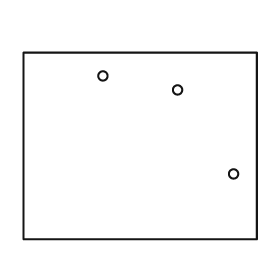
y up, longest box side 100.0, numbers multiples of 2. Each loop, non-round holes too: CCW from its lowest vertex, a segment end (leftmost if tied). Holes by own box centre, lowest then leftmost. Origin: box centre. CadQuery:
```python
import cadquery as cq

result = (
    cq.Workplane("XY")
    .moveTo(-50.0, -40.0)
    .lineTo(50.0, -40.0)
    .lineTo(50.0, 40.0)
    .lineTo(-50.0, 40.0)
    .close()
    .moveTo(40.0, -12.0)
    .circle(2.0)
    .moveTo(16.0, 24.0)
    .circle(2.0)
    .moveTo(-16.0, 30.0)
    .circle(2.0)
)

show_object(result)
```